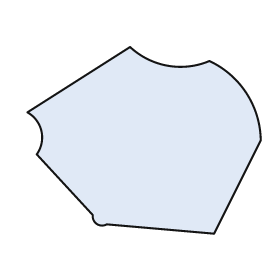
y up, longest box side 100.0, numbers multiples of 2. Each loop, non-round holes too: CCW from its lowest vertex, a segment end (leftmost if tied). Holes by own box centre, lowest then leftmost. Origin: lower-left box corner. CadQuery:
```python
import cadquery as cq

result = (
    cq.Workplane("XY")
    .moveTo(80.0, 0.0)
    .lineTo(100.0, 40.0)
    .threePointArc((94.0, 60.0), (78.0, 74.0))
    .threePointArc((60.0, 72.0), (44.0, 80.0))
    .lineTo(0.0, 52.0)
    .threePointArc((6.0, 44.0), (4.0, 34.0))
    .lineTo(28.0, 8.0)
    .threePointArc((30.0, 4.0), (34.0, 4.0))
    .close()
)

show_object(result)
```